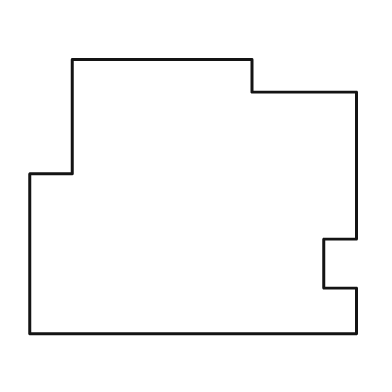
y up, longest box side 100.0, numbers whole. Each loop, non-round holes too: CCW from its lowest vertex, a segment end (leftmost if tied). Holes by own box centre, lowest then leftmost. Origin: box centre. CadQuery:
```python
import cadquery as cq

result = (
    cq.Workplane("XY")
    .moveTo(-50.0, -42.0)
    .lineTo(50.0, -42.0)
    .lineTo(50.0, -28.0)
    .lineTo(40.0, -28.0)
    .lineTo(40.0, -13.0)
    .lineTo(50.0, -13.0)
    .lineTo(50.0, 32.0)
    .lineTo(18.0, 32.0)
    .lineTo(18.0, 42.0)
    .lineTo(-37.0, 42.0)
    .lineTo(-37.0, 7.0)
    .lineTo(-50.0, 7.0)
    .close()
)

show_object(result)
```